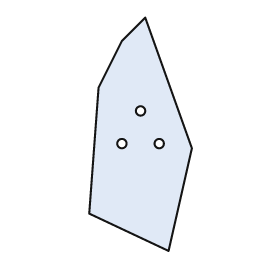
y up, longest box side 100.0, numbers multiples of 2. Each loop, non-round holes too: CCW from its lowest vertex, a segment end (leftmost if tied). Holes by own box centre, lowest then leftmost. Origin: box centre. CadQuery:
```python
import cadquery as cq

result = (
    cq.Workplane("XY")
    .moveTo(12.0, -50.0)
    .lineTo(22.0, -6.0)
    .lineTo(2.0, 50.0)
    .lineTo(-8.0, 40.0)
    .lineTo(-18.0, 20.0)
    .lineTo(-22.0, -34.0)
    .close()
    .moveTo(-8.0, -4.0)
    .circle(2.0)
    .moveTo(8.0, -4.0)
    .circle(2.0)
    .moveTo(0.0, 10.0)
    .circle(2.0)
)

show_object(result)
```